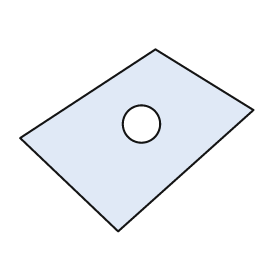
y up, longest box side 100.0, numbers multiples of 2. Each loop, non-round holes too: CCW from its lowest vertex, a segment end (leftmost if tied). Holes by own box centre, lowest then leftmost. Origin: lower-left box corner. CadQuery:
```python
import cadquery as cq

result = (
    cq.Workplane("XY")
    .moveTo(42.0, 0.0)
    .lineTo(100.0, 52.0)
    .lineTo(58.0, 78.0)
    .lineTo(0.0, 40.0)
    .close()
    .moveTo(52.0, 46.0)
    .circle(8.0)
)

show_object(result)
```